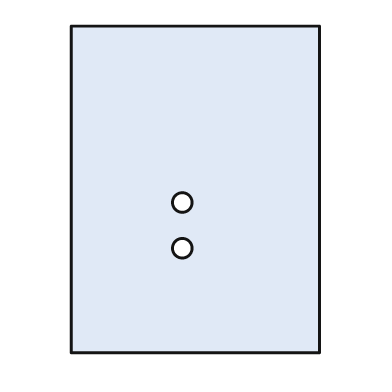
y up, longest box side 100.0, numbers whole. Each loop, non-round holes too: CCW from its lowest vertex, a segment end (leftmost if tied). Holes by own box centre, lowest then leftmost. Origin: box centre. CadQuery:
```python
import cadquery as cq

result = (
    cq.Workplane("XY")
    .moveTo(-38.0, -50.0)
    .lineTo(38.0, -50.0)
    .lineTo(38.0, 50.0)
    .lineTo(-38.0, 50.0)
    .close()
    .moveTo(-4.0, -18.0)
    .circle(3.0)
    .moveTo(-4.0, -4.0)
    .circle(3.0)
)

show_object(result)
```